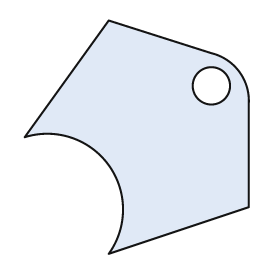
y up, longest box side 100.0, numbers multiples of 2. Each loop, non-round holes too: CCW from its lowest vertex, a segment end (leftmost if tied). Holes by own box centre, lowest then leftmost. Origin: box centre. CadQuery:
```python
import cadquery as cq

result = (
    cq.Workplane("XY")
    .moveTo(-12.0, -50.0)
    .lineTo(48.0, -30.0)
    .lineTo(48.0, 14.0)
    .threePointArc((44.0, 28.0), (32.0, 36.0))
    .lineTo(-12.0, 50.0)
    .lineTo(-48.0, 0.0)
    .threePointArc((-12.0, -12.0), (-12.0, -50.0))
    .close()
    .moveTo(32.0, 22.0)
    .circle(8.0)
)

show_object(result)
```